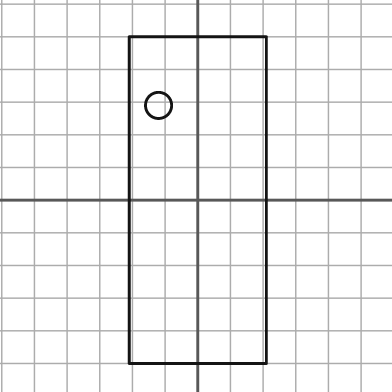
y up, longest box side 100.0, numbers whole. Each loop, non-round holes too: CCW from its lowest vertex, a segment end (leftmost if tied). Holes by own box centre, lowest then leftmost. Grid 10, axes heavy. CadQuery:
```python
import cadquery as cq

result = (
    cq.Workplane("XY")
    .moveTo(-21.0, -50.0)
    .lineTo(21.0, -50.0)
    .lineTo(21.0, 50.0)
    .lineTo(-21.0, 50.0)
    .close()
    .moveTo(-12.0, 29.0)
    .circle(4.0)
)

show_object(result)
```